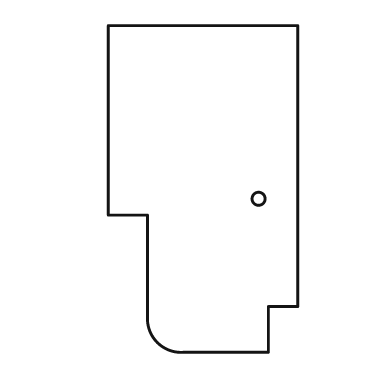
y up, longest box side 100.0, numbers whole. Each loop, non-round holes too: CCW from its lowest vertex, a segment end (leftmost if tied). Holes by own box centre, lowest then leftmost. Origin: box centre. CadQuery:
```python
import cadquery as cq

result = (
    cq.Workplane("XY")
    .moveTo(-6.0, -50.0)
    .lineTo(20.0, -50.0)
    .lineTo(20.0, -36.0)
    .lineTo(29.0, -36.0)
    .lineTo(29.0, 50.0)
    .lineTo(-29.0, 50.0)
    .lineTo(-29.0, -8.0)
    .lineTo(-17.0, -8.0)
    .lineTo(-17.0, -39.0)
    .threePointArc((-14.0, -47.0), (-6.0, -50.0))
    .close()
    .moveTo(17.0, -3.0)
    .circle(2.0)
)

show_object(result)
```